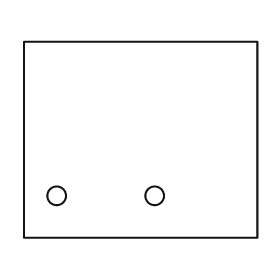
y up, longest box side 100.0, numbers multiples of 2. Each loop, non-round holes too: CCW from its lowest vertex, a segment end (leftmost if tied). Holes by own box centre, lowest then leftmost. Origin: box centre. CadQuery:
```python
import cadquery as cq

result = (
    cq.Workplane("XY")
    .moveTo(-50.0, -42.0)
    .lineTo(50.0, -42.0)
    .lineTo(50.0, 42.0)
    .lineTo(-50.0, 42.0)
    .close()
    .moveTo(-36.0, -24.0)
    .circle(4.0)
    .moveTo(6.0, -24.0)
    .circle(4.0)
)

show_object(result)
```